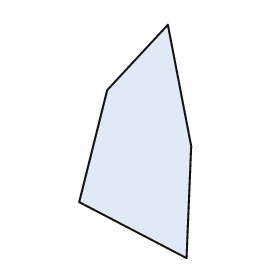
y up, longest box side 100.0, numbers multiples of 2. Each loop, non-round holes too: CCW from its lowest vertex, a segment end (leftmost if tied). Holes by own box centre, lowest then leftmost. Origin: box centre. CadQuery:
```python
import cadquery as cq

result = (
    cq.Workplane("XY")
    .moveTo(22.0, -50.0)
    .lineTo(24.0, -2.0)
    .lineTo(14.0, 50.0)
    .lineTo(-12.0, 22.0)
    .lineTo(-24.0, -26.0)
    .close()
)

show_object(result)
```